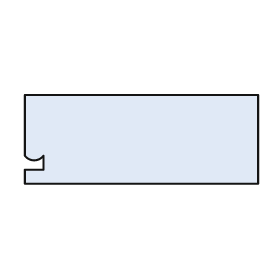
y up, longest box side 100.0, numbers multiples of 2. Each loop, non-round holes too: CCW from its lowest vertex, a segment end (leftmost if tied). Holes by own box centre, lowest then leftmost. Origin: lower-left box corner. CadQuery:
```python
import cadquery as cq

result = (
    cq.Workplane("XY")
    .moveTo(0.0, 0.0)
    .lineTo(100.0, 0.0)
    .lineTo(100.0, 38.0)
    .lineTo(0.0, 38.0)
    .lineTo(0.0, 12.0)
    .threePointArc((4.0, 10.0), (8.0, 12.0))
    .lineTo(8.0, 6.0)
    .lineTo(0.0, 6.0)
    .close()
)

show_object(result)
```